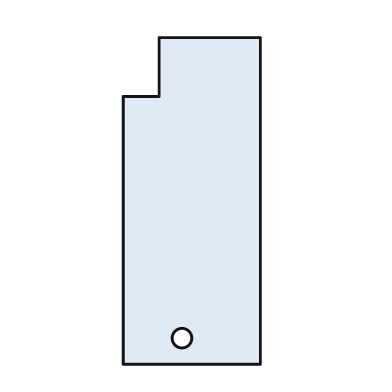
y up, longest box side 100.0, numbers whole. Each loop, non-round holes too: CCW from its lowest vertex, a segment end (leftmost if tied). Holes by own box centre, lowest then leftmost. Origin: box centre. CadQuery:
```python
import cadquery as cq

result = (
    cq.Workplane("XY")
    .moveTo(-21.0, -50.0)
    .lineTo(21.0, -50.0)
    .lineTo(21.0, 50.0)
    .lineTo(-10.0, 50.0)
    .lineTo(-10.0, 32.0)
    .lineTo(-21.0, 32.0)
    .close()
    .moveTo(-3.0, -42.0)
    .circle(3.0)
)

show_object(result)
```